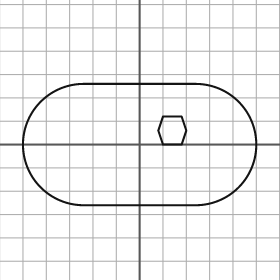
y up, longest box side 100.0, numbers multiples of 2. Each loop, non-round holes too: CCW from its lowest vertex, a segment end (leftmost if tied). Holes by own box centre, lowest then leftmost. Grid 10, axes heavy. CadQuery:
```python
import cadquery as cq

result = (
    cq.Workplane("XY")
    .moveTo(-24.0, -26.0)
    .lineTo(24.0, -26.0)
    .threePointArc((50.0, 0.0), (24.0, 26.0))
    .lineTo(-24.0, 26.0)
    .threePointArc((-50.0, 0.0), (-24.0, -26.0))
    .close()
    .moveTo(10.0, 0.0)
    .lineTo(18.0, 0.0)
    .lineTo(20.0, 6.0)
    .lineTo(18.0, 12.0)
    .lineTo(10.0, 12.0)
    .lineTo(8.0, 6.0)
    .close()
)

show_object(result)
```